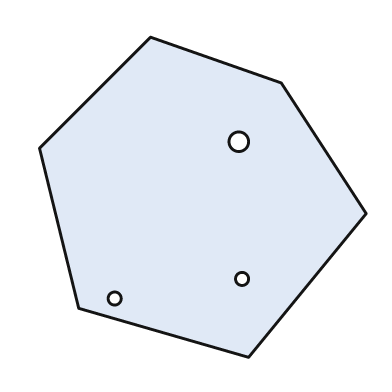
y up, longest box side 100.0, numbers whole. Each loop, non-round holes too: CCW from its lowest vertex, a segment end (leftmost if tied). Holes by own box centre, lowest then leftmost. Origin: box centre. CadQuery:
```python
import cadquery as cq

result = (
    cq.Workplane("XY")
    .moveTo(14.0, -49.0)
    .lineTo(50.0, -5.0)
    .lineTo(24.0, 35.0)
    .lineTo(-16.0, 49.0)
    .lineTo(-50.0, 15.0)
    .lineTo(-38.0, -34.0)
    .close()
    .moveTo(-27.0, -31.0)
    .circle(2.0)
    .moveTo(12.0, -25.0)
    .circle(2.0)
    .moveTo(11.0, 17.0)
    .circle(3.0)
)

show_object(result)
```